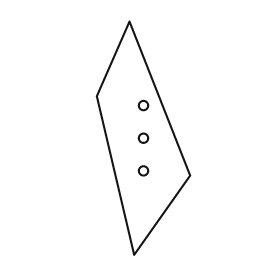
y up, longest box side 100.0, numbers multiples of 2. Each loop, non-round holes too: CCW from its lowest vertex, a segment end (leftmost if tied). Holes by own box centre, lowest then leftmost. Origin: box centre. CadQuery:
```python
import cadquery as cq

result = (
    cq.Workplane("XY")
    .moveTo(-4.0, -50.0)
    .lineTo(20.0, -16.0)
    .lineTo(-6.0, 50.0)
    .lineTo(-20.0, 18.0)
    .close()
    .moveTo(0.0, -14.0)
    .circle(2.0)
    .moveTo(0.0, 0.0)
    .circle(2.0)
    .moveTo(0.0, 14.0)
    .circle(2.0)
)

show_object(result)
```